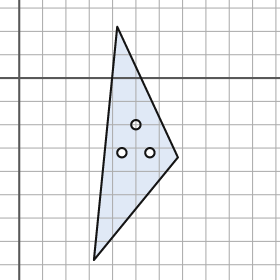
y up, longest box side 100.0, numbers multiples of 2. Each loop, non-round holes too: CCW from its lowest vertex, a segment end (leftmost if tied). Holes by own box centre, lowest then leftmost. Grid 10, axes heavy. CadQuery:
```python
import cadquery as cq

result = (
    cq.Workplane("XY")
    .moveTo(32.0, -78.0)
    .lineTo(68.0, -34.0)
    .lineTo(42.0, 22.0)
    .close()
    .moveTo(44.0, -32.0)
    .circle(2.0)
    .moveTo(56.0, -32.0)
    .circle(2.0)
    .moveTo(50.0, -20.0)
    .circle(2.0)
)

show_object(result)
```